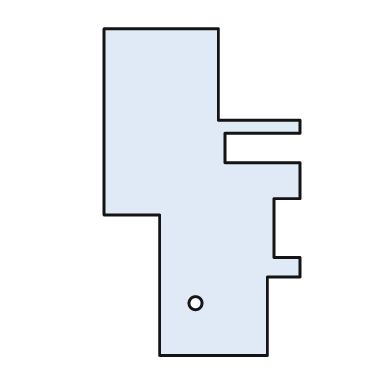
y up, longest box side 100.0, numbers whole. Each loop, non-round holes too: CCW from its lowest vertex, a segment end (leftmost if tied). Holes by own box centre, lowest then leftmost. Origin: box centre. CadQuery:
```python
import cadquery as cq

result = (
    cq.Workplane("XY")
    .moveTo(-13.0, -50.0)
    .lineTo(20.0, -50.0)
    .lineTo(20.0, -26.0)
    .lineTo(30.0, -26.0)
    .lineTo(30.0, -20.0)
    .lineTo(22.0, -20.0)
    .lineTo(22.0, -2.0)
    .lineTo(30.0, -2.0)
    .lineTo(30.0, 9.0)
    .lineTo(7.0, 9.0)
    .lineTo(7.0, 18.0)
    .lineTo(30.0, 18.0)
    .lineTo(30.0, 22.0)
    .lineTo(5.0, 22.0)
    .lineTo(5.0, 50.0)
    .lineTo(-30.0, 50.0)
    .lineTo(-30.0, -7.0)
    .lineTo(-13.0, -7.0)
    .close()
    .moveTo(-2.0, -34.0)
    .circle(2.0)
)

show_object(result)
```